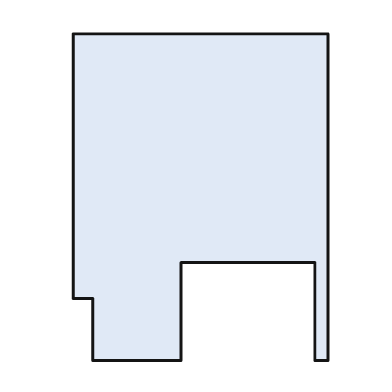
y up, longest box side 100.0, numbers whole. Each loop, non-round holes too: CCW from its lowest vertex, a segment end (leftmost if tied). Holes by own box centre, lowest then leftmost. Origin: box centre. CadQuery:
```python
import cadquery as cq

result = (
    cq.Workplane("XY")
    .moveTo(-33.0, -50.0)
    .lineTo(-6.0, -50.0)
    .lineTo(-6.0, -20.0)
    .lineTo(35.0, -20.0)
    .lineTo(35.0, -50.0)
    .lineTo(39.0, -50.0)
    .lineTo(39.0, 50.0)
    .lineTo(-39.0, 50.0)
    .lineTo(-39.0, -31.0)
    .lineTo(-33.0, -31.0)
    .close()
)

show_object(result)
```